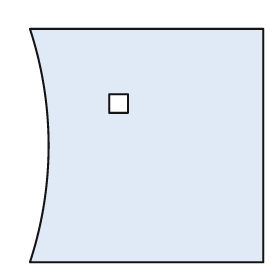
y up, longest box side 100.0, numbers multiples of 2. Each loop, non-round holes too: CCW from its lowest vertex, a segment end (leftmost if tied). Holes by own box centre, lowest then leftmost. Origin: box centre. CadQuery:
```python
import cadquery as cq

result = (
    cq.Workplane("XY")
    .moveTo(-50.0, -50.0)
    .lineTo(50.0, -50.0)
    .lineTo(50.0, 50.0)
    .lineTo(-50.0, 50.0)
    .threePointArc((-42.0, 0.0), (-50.0, -50.0))
    .close()
    .moveTo(-16.0, 14.0)
    .lineTo(-8.0, 14.0)
    .lineTo(-8.0, 22.0)
    .lineTo(-16.0, 22.0)
    .close()
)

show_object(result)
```